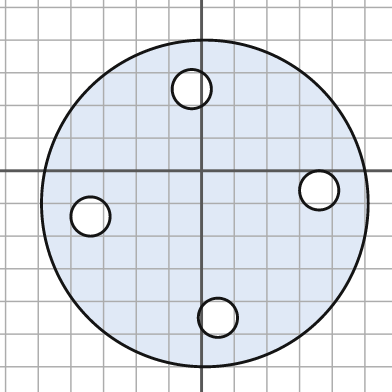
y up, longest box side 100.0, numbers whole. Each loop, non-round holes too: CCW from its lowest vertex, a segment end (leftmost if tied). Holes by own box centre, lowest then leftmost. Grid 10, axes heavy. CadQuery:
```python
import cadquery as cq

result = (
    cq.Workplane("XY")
    .moveTo(1.0, -10.0)
    .circle(50.0)
    .moveTo(5.0, -45.0)
    .circle(6.0)
    .moveTo(-34.0, -14.0)
    .circle(6.0)
    .moveTo(36.0, -6.0)
    .circle(6.0)
    .moveTo(-3.0, 25.0)
    .circle(6.0)
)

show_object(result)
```